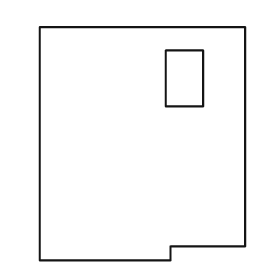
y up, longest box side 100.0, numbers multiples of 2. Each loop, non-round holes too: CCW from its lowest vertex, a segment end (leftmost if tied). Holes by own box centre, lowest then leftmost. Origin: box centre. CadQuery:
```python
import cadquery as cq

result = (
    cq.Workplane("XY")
    .moveTo(-44.0, -50.0)
    .lineTo(12.0, -50.0)
    .lineTo(12.0, -44.0)
    .lineTo(44.0, -44.0)
    .lineTo(44.0, 50.0)
    .lineTo(-44.0, 50.0)
    .close()
    .moveTo(10.0, 16.0)
    .lineTo(26.0, 16.0)
    .lineTo(26.0, 40.0)
    .lineTo(10.0, 40.0)
    .close()
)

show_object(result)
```